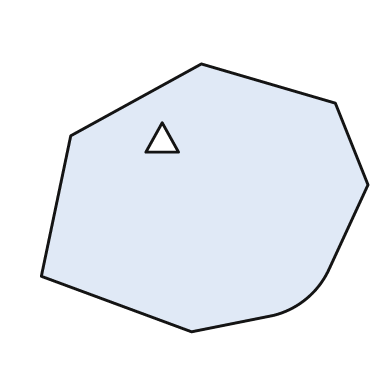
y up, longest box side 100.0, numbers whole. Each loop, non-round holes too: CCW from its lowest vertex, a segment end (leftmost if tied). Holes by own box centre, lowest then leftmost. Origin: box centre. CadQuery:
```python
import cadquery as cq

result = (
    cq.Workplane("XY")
    .moveTo(-4.0, -41.0)
    .lineTo(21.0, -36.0)
    .threePointArc((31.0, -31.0), (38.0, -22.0))
    .lineTo(50.0, 4.0)
    .lineTo(40.0, 29.0)
    .lineTo(-1.0, 41.0)
    .lineTo(-41.0, 19.0)
    .lineTo(-50.0, -24.0)
    .close()
    .moveTo(-18.0, 14.0)
    .lineTo(-8.0, 14.0)
    .lineTo(-13.0, 23.0)
    .close()
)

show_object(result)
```